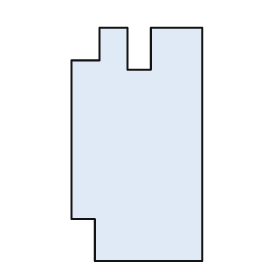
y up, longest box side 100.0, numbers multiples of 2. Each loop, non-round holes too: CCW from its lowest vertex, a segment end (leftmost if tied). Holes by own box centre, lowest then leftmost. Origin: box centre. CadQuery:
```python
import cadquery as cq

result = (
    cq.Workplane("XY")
    .moveTo(-18.0, -50.0)
    .lineTo(28.0, -50.0)
    .lineTo(28.0, 50.0)
    .lineTo(6.0, 50.0)
    .lineTo(6.0, 32.0)
    .lineTo(-4.0, 32.0)
    .lineTo(-4.0, 50.0)
    .lineTo(-16.0, 50.0)
    .lineTo(-16.0, 36.0)
    .lineTo(-28.0, 36.0)
    .lineTo(-28.0, -32.0)
    .lineTo(-18.0, -32.0)
    .close()
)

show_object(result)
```